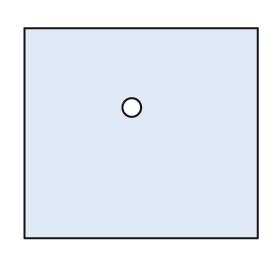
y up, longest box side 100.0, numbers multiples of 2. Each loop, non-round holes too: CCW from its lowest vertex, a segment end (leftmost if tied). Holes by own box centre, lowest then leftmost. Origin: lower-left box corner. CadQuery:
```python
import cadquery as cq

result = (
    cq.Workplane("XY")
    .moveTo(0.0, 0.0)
    .lineTo(100.0, 0.0)
    .lineTo(100.0, 90.0)
    .lineTo(0.0, 90.0)
    .close()
    .moveTo(46.0, 56.0)
    .circle(4.0)
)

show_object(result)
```